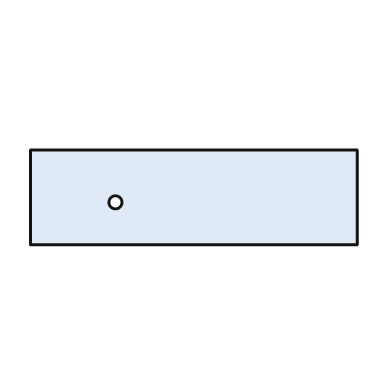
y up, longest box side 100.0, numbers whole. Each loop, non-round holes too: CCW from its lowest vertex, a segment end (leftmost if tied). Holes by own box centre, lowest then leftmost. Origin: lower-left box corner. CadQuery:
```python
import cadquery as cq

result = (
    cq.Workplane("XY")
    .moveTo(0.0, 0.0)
    .lineTo(100.0, 0.0)
    .lineTo(100.0, 29.0)
    .lineTo(0.0, 29.0)
    .close()
    .moveTo(26.0, 13.0)
    .circle(2.0)
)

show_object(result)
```